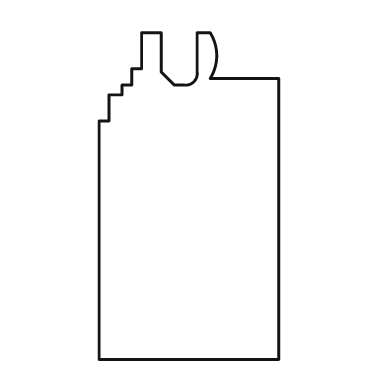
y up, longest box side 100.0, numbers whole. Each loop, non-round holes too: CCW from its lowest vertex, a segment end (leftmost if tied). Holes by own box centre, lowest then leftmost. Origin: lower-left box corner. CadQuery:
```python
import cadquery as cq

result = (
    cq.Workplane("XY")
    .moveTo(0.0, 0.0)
    .lineTo(55.0, 0.0)
    .lineTo(55.0, 86.0)
    .lineTo(34.0, 86.0)
    .threePointArc((36.0, 93.0), (34.0, 100.0))
    .lineTo(30.0, 100.0)
    .lineTo(30.0, 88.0)
    .threePointArc((29.0, 85.0), (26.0, 84.0))
    .lineTo(23.0, 84.0)
    .lineTo(19.0, 88.0)
    .lineTo(19.0, 100.0)
    .lineTo(13.0, 100.0)
    .lineTo(13.0, 89.0)
    .lineTo(10.0, 89.0)
    .lineTo(10.0, 84.0)
    .lineTo(7.0, 84.0)
    .lineTo(7.0, 81.0)
    .lineTo(3.0, 81.0)
    .lineTo(3.0, 73.0)
    .lineTo(0.0, 73.0)
    .close()
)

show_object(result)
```